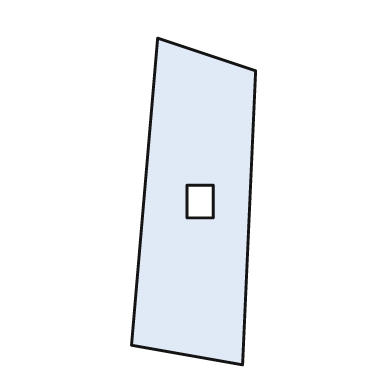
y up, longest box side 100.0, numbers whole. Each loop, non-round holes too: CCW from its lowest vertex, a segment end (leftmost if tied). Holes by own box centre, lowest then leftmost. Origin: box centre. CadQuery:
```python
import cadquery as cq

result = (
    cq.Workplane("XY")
    .moveTo(15.0, -50.0)
    .lineTo(19.0, 40.0)
    .lineTo(-11.0, 50.0)
    .lineTo(-19.0, -44.0)
    .close()
    .moveTo(-2.0, -5.0)
    .lineTo(6.0, -5.0)
    .lineTo(6.0, 5.0)
    .lineTo(-2.0, 5.0)
    .close()
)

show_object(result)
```